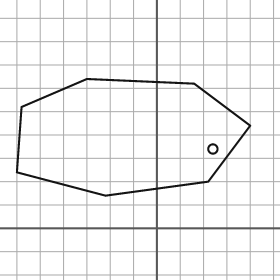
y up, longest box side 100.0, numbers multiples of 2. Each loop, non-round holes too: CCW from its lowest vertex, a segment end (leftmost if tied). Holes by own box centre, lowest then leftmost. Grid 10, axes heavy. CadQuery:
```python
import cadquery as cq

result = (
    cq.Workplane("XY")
    .moveTo(-22.0, 14.0)
    .lineTo(22.0, 20.0)
    .lineTo(40.0, 44.0)
    .lineTo(16.0, 62.0)
    .lineTo(-30.0, 64.0)
    .lineTo(-58.0, 52.0)
    .lineTo(-60.0, 24.0)
    .close()
    .moveTo(24.0, 34.0)
    .circle(2.0)
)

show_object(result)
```